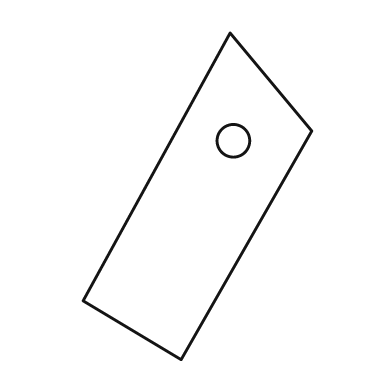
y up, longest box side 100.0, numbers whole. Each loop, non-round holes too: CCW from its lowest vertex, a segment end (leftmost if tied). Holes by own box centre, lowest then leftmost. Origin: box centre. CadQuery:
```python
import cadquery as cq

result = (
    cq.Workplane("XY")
    .moveTo(-5.0, -50.0)
    .lineTo(35.0, 20.0)
    .lineTo(10.0, 50.0)
    .lineTo(-35.0, -32.0)
    .close()
    .moveTo(11.0, 17.0)
    .circle(5.0)
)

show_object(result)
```